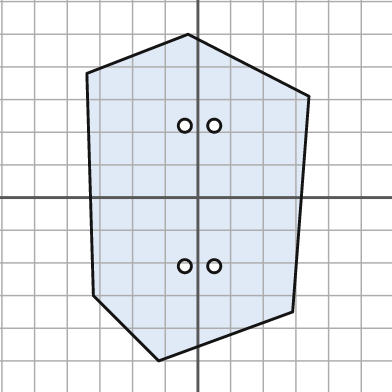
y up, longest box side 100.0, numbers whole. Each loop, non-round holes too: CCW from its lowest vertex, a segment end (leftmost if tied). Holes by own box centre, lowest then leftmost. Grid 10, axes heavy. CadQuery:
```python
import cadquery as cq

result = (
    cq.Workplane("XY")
    .moveTo(-12.0, -50.0)
    .lineTo(29.0, -35.0)
    .lineTo(34.0, 31.0)
    .lineTo(-3.0, 50.0)
    .lineTo(-34.0, 38.0)
    .lineTo(-32.0, -30.0)
    .close()
    .moveTo(-4.0, -21.0)
    .circle(2.0)
    .moveTo(5.0, -21.0)
    .circle(2.0)
    .moveTo(-4.0, 22.0)
    .circle(2.0)
    .moveTo(5.0, 22.0)
    .circle(2.0)
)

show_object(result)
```